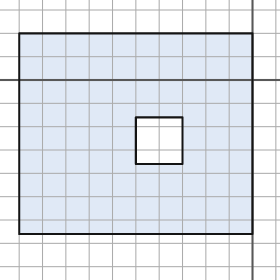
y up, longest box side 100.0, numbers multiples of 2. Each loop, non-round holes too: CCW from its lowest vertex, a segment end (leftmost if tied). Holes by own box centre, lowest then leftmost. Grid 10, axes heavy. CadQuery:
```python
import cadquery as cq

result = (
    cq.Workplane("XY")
    .moveTo(-100.0, -66.0)
    .lineTo(0.0, -66.0)
    .lineTo(0.0, 20.0)
    .lineTo(-100.0, 20.0)
    .close()
    .moveTo(-50.0, -36.0)
    .lineTo(-30.0, -36.0)
    .lineTo(-30.0, -16.0)
    .lineTo(-50.0, -16.0)
    .close()
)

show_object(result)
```